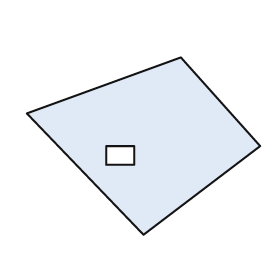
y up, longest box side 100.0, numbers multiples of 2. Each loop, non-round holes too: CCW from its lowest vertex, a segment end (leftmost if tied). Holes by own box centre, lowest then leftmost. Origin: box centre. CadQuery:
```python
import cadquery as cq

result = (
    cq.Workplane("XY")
    .moveTo(0.0, -38.0)
    .lineTo(50.0, 0.0)
    .lineTo(16.0, 38.0)
    .lineTo(-50.0, 14.0)
    .close()
    .moveTo(-16.0, -8.0)
    .lineTo(-4.0, -8.0)
    .lineTo(-4.0, 0.0)
    .lineTo(-16.0, 0.0)
    .close()
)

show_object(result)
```